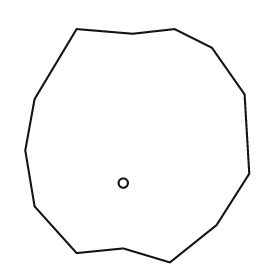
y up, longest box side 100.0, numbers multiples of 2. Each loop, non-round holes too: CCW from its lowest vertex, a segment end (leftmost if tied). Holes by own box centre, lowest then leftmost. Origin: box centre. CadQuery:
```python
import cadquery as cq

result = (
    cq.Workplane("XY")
    .moveTo(14.0, -50.0)
    .lineTo(34.0, -34.0)
    .lineTo(48.0, -12.0)
    .lineTo(46.0, 22.0)
    .lineTo(32.0, 42.0)
    .lineTo(16.0, 50.0)
    .lineTo(-2.0, 48.0)
    .lineTo(-26.0, 50.0)
    .lineTo(-44.0, 20.0)
    .lineTo(-48.0, -2.0)
    .lineTo(-44.0, -26.0)
    .lineTo(-26.0, -46.0)
    .lineTo(-6.0, -44.0)
    .close()
    .moveTo(-6.0, -16.0)
    .circle(2.0)
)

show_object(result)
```